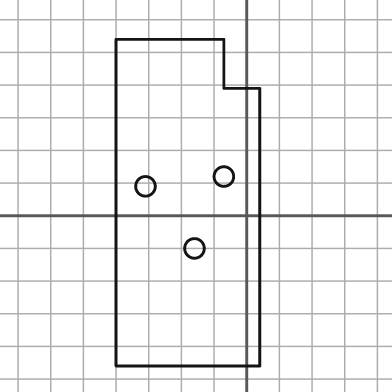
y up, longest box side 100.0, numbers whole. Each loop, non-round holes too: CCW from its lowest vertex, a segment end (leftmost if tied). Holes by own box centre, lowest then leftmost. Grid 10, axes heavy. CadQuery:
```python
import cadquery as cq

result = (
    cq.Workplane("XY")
    .moveTo(-40.0, -46.0)
    .lineTo(4.0, -46.0)
    .lineTo(4.0, 39.0)
    .lineTo(-7.0, 39.0)
    .lineTo(-7.0, 54.0)
    .lineTo(-40.0, 54.0)
    .close()
    .moveTo(-16.0, -10.0)
    .circle(3.0)
    .moveTo(-31.0, 9.0)
    .circle(3.0)
    .moveTo(-7.0, 12.0)
    .circle(3.0)
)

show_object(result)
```